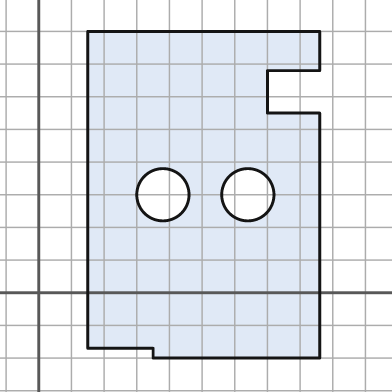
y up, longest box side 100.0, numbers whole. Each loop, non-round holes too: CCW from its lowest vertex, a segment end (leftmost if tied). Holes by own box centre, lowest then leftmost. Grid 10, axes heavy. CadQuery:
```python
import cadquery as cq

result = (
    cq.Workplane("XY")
    .moveTo(35.0, -20.0)
    .lineTo(86.0, -20.0)
    .lineTo(86.0, 55.0)
    .lineTo(70.0, 55.0)
    .lineTo(70.0, 68.0)
    .lineTo(86.0, 68.0)
    .lineTo(86.0, 80.0)
    .lineTo(15.0, 80.0)
    .lineTo(15.0, -17.0)
    .lineTo(35.0, -17.0)
    .close()
    .moveTo(38.0, 30.0)
    .circle(8.0)
    .moveTo(64.0, 30.0)
    .circle(8.0)
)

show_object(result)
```